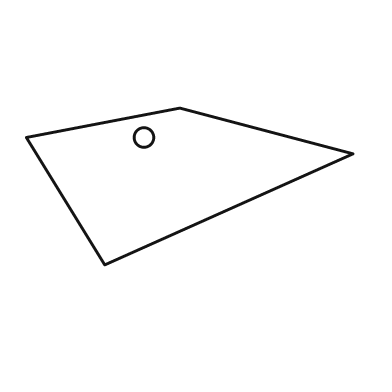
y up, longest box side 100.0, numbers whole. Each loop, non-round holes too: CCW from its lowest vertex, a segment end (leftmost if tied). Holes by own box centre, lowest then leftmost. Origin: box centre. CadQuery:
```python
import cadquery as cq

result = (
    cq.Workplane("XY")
    .moveTo(-26.0, -24.0)
    .lineTo(50.0, 10.0)
    .lineTo(-3.0, 24.0)
    .lineTo(-50.0, 15.0)
    .close()
    .moveTo(-14.0, 15.0)
    .circle(3.0)
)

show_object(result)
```